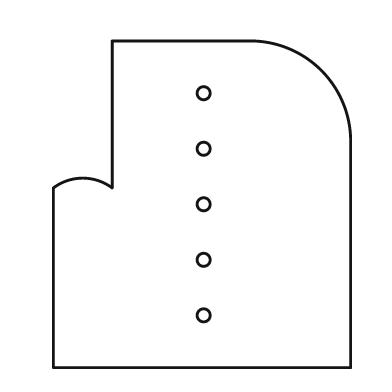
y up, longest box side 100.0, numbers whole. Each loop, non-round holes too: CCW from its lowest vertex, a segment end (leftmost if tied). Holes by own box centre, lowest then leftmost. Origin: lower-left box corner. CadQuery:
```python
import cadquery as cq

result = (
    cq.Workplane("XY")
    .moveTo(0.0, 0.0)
    .lineTo(91.0, 0.0)
    .lineTo(91.0, 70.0)
    .threePointArc((82.0, 91.0), (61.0, 100.0))
    .lineTo(18.0, 100.0)
    .lineTo(18.0, 55.0)
    .threePointArc((9.0, 58.0), (0.0, 55.0))
    .close()
    .moveTo(46.0, 16.0)
    .circle(2.0)
    .moveTo(46.0, 33.0)
    .circle(2.0)
    .moveTo(46.0, 50.0)
    .circle(2.0)
    .moveTo(46.0, 67.0)
    .circle(2.0)
    .moveTo(46.0, 84.0)
    .circle(2.0)
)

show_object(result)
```